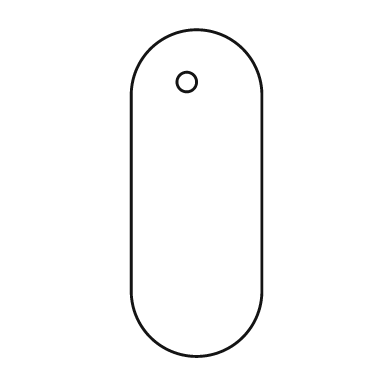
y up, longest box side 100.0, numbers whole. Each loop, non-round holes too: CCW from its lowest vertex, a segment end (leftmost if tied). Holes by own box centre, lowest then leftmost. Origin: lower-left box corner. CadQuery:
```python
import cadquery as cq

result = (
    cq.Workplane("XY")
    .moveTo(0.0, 20.0)
    .threePointArc((20.0, 0.0), (40.0, 20.0))
    .lineTo(40.0, 80.0)
    .threePointArc((20.0, 100.0), (0.0, 80.0))
    .close()
    .moveTo(17.0, 84.0)
    .circle(3.0)
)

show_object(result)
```